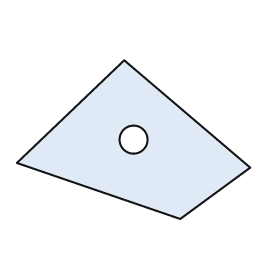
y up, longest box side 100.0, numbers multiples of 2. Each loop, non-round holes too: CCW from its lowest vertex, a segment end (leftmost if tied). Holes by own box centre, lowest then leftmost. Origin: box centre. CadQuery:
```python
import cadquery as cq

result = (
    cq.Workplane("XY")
    .moveTo(20.0, -34.0)
    .lineTo(50.0, -12.0)
    .lineTo(-4.0, 34.0)
    .lineTo(-50.0, -10.0)
    .close()
    .moveTo(0.0, 0.0)
    .circle(6.0)
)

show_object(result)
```